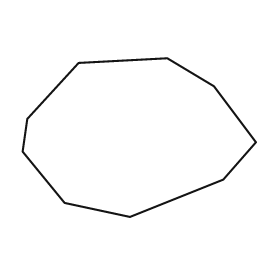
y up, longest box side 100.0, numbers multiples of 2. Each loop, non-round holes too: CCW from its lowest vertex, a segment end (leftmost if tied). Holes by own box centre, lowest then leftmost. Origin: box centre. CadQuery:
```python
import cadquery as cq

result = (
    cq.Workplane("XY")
    .moveTo(-4.0, -34.0)
    .lineTo(36.0, -18.0)
    .lineTo(50.0, -2.0)
    .lineTo(32.0, 22.0)
    .lineTo(12.0, 34.0)
    .lineTo(-26.0, 32.0)
    .lineTo(-48.0, 8.0)
    .lineTo(-50.0, -6.0)
    .lineTo(-32.0, -28.0)
    .close()
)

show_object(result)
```